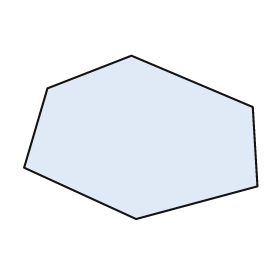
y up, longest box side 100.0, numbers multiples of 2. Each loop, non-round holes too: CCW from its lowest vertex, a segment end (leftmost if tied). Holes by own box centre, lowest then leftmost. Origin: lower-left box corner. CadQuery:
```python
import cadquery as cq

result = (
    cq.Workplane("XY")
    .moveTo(48.0, 0.0)
    .lineTo(100.0, 14.0)
    .lineTo(98.0, 48.0)
    .lineTo(46.0, 70.0)
    .lineTo(10.0, 56.0)
    .lineTo(0.0, 22.0)
    .close()
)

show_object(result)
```